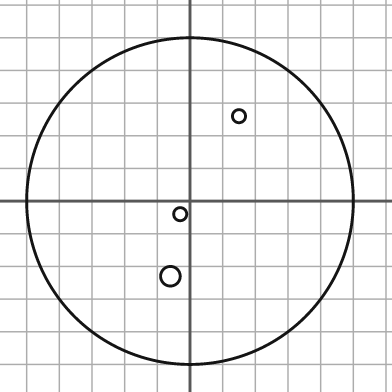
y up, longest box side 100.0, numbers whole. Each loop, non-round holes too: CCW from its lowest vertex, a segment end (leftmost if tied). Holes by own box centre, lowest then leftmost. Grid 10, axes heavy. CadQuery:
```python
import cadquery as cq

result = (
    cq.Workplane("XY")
    .moveTo(0.0, 0.0)
    .circle(50.0)
    .moveTo(-6.0, -23.0)
    .circle(3.0)
    .moveTo(-3.0, -4.0)
    .circle(2.0)
    .moveTo(15.0, 26.0)
    .circle(2.0)
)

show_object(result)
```